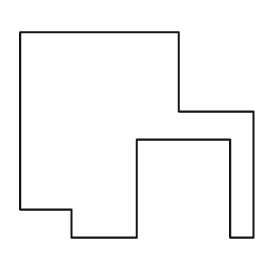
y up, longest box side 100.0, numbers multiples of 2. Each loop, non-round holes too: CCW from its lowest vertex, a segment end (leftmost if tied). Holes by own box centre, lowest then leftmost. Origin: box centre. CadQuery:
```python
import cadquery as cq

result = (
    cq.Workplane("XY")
    .moveTo(-28.0, -44.0)
    .lineTo(0.0, -44.0)
    .lineTo(0.0, -2.0)
    .lineTo(40.0, -2.0)
    .lineTo(40.0, -44.0)
    .lineTo(50.0, -44.0)
    .lineTo(50.0, 10.0)
    .lineTo(18.0, 10.0)
    .lineTo(18.0, 44.0)
    .lineTo(-50.0, 44.0)
    .lineTo(-50.0, -32.0)
    .lineTo(-28.0, -32.0)
    .close()
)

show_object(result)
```